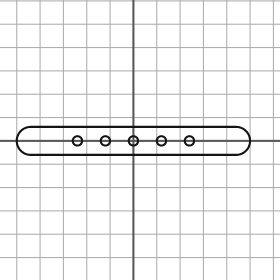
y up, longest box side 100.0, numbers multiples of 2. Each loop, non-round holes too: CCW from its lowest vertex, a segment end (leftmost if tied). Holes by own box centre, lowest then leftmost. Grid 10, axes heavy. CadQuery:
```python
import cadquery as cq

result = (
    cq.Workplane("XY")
    .moveTo(-44.0, -6.0)
    .lineTo(44.0, -6.0)
    .threePointArc((50.0, 0.0), (44.0, 6.0))
    .lineTo(-44.0, 6.0)
    .threePointArc((-50.0, 0.0), (-44.0, -6.0))
    .close()
    .moveTo(-24.0, 0.0)
    .circle(2.0)
    .moveTo(-12.0, 0.0)
    .circle(2.0)
    .moveTo(0.0, 0.0)
    .circle(2.0)
    .moveTo(12.0, 0.0)
    .circle(2.0)
    .moveTo(24.0, 0.0)
    .circle(2.0)
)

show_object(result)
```